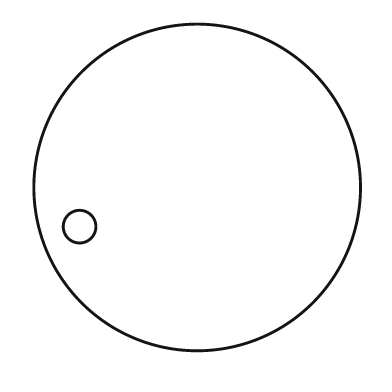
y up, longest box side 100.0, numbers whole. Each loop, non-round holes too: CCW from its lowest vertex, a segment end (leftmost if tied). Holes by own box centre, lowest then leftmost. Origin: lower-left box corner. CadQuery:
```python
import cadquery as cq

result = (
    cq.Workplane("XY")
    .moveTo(50.0, 50.0)
    .circle(50.0)
    .moveTo(14.0, 38.0)
    .circle(5.0)
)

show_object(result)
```